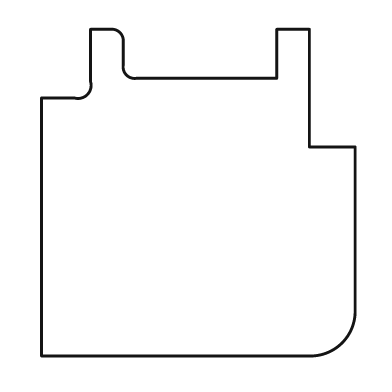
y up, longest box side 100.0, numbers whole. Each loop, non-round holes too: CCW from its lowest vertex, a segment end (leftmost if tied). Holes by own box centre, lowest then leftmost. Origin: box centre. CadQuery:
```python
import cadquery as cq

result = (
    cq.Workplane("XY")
    .moveTo(-48.0, -50.0)
    .lineTo(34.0, -50.0)
    .threePointArc((44.0, -46.0), (48.0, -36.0))
    .lineTo(48.0, 14.0)
    .lineTo(34.0, 14.0)
    .lineTo(34.0, 50.0)
    .lineTo(24.0, 50.0)
    .lineTo(24.0, 35.0)
    .lineTo(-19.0, 35.0)
    .threePointArc((-22.0, 36.0), (-23.0, 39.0))
    .lineTo(-23.0, 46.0)
    .threePointArc((-24.0, 49.0), (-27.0, 50.0))
    .lineTo(-33.0, 50.0)
    .lineTo(-33.0, 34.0)
    .threePointArc((-34.0, 30.0), (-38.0, 29.0))
    .lineTo(-48.0, 29.0)
    .close()
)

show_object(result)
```